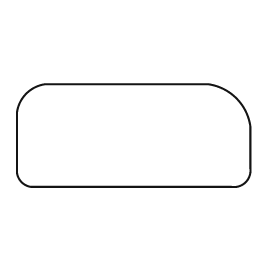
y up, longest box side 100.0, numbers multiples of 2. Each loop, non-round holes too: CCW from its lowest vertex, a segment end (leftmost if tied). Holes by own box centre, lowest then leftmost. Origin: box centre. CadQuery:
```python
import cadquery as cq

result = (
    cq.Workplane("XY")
    .moveTo(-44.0, -22.0)
    .lineTo(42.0, -22.0)
    .threePointArc((48.0, -20.0), (50.0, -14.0))
    .lineTo(50.0, 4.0)
    .threePointArc((44.0, 16.0), (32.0, 22.0))
    .lineTo(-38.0, 22.0)
    .threePointArc((-46.0, 18.0), (-50.0, 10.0))
    .lineTo(-50.0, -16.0)
    .threePointArc((-48.0, -20.0), (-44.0, -22.0))
    .close()
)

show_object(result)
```